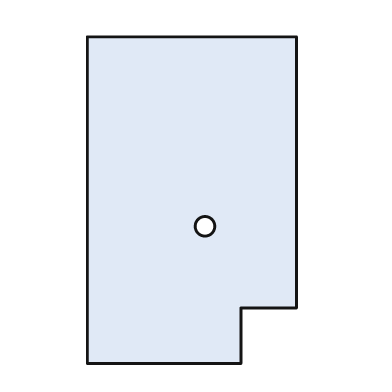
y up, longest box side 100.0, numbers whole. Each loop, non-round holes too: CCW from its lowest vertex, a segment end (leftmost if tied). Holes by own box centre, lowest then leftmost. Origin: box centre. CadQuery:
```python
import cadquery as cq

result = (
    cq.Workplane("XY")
    .moveTo(-32.0, -50.0)
    .lineTo(15.0, -50.0)
    .lineTo(15.0, -33.0)
    .lineTo(32.0, -33.0)
    .lineTo(32.0, 50.0)
    .lineTo(-32.0, 50.0)
    .close()
    .moveTo(4.0, -8.0)
    .circle(3.0)
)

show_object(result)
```